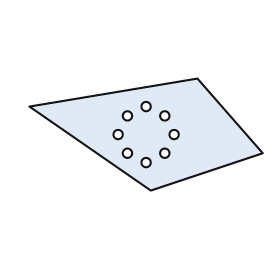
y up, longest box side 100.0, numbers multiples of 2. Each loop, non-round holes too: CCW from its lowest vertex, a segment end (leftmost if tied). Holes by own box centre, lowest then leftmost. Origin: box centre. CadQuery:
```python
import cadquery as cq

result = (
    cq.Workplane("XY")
    .moveTo(2.0, -24.0)
    .lineTo(50.0, -8.0)
    .lineTo(22.0, 24.0)
    .lineTo(-50.0, 12.0)
    .close()
    .moveTo(0.0, -12.0)
    .circle(2.0)
    .moveTo(-8.0, -8.0)
    .circle(2.0)
    .moveTo(8.0, -8.0)
    .circle(2.0)
    .moveTo(-12.0, 0.0)
    .circle(2.0)
    .moveTo(12.0, 0.0)
    .circle(2.0)
    .moveTo(-8.0, 8.0)
    .circle(2.0)
    .moveTo(8.0, 8.0)
    .circle(2.0)
    .moveTo(0.0, 12.0)
    .circle(2.0)
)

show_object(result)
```